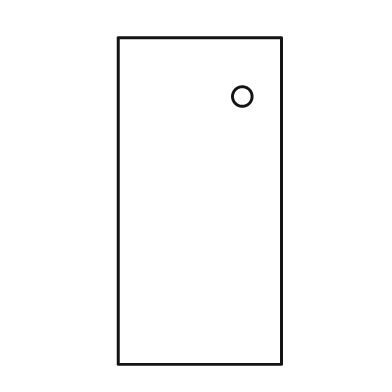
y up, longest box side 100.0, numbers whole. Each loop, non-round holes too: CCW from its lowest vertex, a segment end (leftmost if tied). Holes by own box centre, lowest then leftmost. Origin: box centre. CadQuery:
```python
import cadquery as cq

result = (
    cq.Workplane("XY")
    .moveTo(-25.0, -50.0)
    .lineTo(25.0, -50.0)
    .lineTo(25.0, 50.0)
    .lineTo(-25.0, 50.0)
    .close()
    .moveTo(13.0, 32.0)
    .circle(3.0)
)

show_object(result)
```